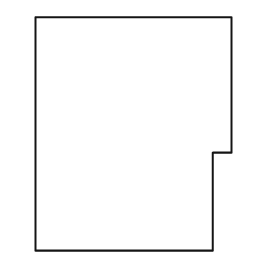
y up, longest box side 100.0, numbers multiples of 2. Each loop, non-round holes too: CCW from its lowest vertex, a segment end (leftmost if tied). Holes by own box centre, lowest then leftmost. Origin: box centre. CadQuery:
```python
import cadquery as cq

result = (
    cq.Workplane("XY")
    .moveTo(-42.0, -50.0)
    .lineTo(34.0, -50.0)
    .lineTo(34.0, -8.0)
    .lineTo(42.0, -8.0)
    .lineTo(42.0, 50.0)
    .lineTo(-42.0, 50.0)
    .close()
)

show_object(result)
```